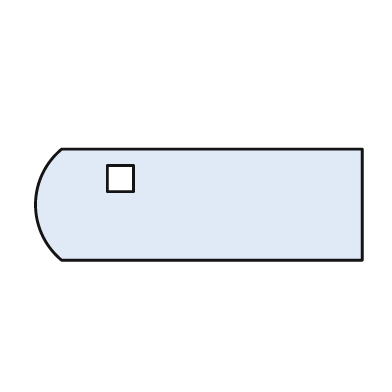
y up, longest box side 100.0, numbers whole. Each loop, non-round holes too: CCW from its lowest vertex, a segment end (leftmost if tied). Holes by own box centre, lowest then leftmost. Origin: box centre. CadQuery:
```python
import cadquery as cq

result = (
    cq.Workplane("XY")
    .moveTo(-42.0, -17.0)
    .lineTo(50.0, -17.0)
    .lineTo(50.0, 17.0)
    .lineTo(-42.0, 17.0)
    .threePointArc((-50.0, 0.0), (-42.0, -17.0))
    .close()
    .moveTo(-28.0, 4.0)
    .lineTo(-20.0, 4.0)
    .lineTo(-20.0, 12.0)
    .lineTo(-28.0, 12.0)
    .close()
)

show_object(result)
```